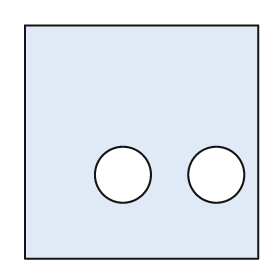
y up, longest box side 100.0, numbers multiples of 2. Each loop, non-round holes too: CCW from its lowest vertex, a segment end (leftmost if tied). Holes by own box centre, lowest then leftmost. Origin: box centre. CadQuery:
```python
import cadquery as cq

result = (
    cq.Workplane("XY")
    .moveTo(-50.0, -50.0)
    .lineTo(50.0, -50.0)
    .lineTo(50.0, 50.0)
    .lineTo(-50.0, 50.0)
    .close()
    .moveTo(-8.0, -14.0)
    .circle(12.0)
    .moveTo(32.0, -14.0)
    .circle(12.0)
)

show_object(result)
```